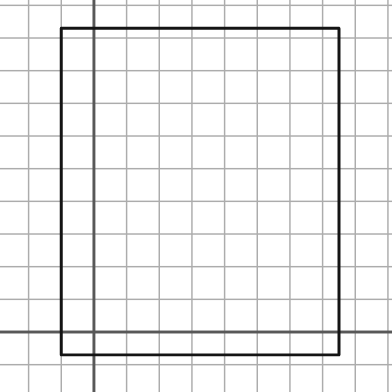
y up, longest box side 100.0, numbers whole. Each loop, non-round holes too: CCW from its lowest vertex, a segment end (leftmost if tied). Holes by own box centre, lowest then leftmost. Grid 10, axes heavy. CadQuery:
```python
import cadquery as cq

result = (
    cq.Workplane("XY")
    .moveTo(-10.0, -7.0)
    .lineTo(75.0, -7.0)
    .lineTo(75.0, 93.0)
    .lineTo(-10.0, 93.0)
    .close()
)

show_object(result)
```